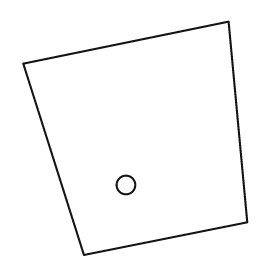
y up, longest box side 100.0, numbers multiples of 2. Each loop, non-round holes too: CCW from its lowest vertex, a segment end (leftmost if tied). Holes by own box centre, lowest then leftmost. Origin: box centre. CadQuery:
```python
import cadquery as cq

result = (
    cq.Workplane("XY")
    .moveTo(-22.0, -50.0)
    .lineTo(48.0, -36.0)
    .lineTo(40.0, 50.0)
    .lineTo(-48.0, 32.0)
    .close()
    .moveTo(-4.0, -20.0)
    .circle(4.0)
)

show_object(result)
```